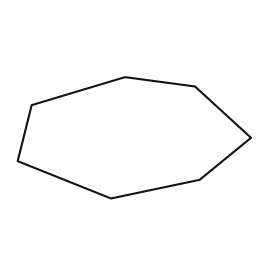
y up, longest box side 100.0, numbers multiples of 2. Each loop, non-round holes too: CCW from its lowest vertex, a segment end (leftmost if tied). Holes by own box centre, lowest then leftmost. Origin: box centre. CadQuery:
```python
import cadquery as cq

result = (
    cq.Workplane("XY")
    .moveTo(-10.0, -26.0)
    .lineTo(28.0, -18.0)
    .lineTo(50.0, 0.0)
    .lineTo(26.0, 22.0)
    .lineTo(-4.0, 26.0)
    .lineTo(-44.0, 14.0)
    .lineTo(-50.0, -10.0)
    .close()
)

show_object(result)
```